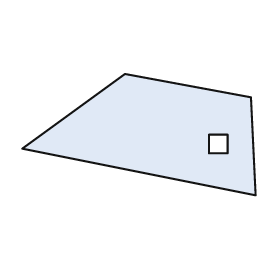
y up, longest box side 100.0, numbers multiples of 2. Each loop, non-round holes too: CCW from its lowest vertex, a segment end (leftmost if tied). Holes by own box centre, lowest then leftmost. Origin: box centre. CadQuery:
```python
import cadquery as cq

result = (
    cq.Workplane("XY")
    .moveTo(50.0, -26.0)
    .lineTo(48.0, 16.0)
    .lineTo(-6.0, 26.0)
    .lineTo(-50.0, -6.0)
    .close()
    .moveTo(30.0, -8.0)
    .lineTo(38.0, -8.0)
    .lineTo(38.0, 0.0)
    .lineTo(30.0, 0.0)
    .close()
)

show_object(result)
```